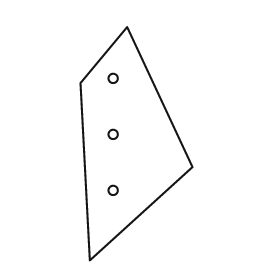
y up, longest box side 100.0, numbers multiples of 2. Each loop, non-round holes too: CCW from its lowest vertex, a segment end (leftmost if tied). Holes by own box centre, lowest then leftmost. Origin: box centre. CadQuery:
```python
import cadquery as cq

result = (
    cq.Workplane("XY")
    .moveTo(-20.0, -50.0)
    .lineTo(24.0, -10.0)
    .lineTo(-4.0, 50.0)
    .lineTo(-24.0, 26.0)
    .close()
    .moveTo(-10.0, -20.0)
    .circle(2.0)
    .moveTo(-10.0, 4.0)
    .circle(2.0)
    .moveTo(-10.0, 28.0)
    .circle(2.0)
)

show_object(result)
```